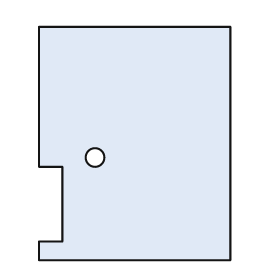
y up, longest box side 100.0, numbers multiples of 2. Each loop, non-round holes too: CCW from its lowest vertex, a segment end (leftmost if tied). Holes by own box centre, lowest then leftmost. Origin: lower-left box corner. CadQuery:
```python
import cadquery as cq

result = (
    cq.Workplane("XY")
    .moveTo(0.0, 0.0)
    .lineTo(82.0, 0.0)
    .lineTo(82.0, 100.0)
    .lineTo(0.0, 100.0)
    .lineTo(0.0, 40.0)
    .lineTo(10.0, 40.0)
    .lineTo(10.0, 8.0)
    .lineTo(0.0, 8.0)
    .close()
    .moveTo(24.0, 44.0)
    .circle(4.0)
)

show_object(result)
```